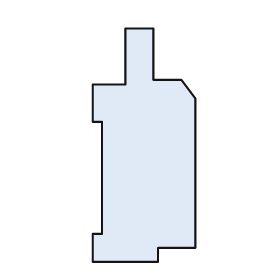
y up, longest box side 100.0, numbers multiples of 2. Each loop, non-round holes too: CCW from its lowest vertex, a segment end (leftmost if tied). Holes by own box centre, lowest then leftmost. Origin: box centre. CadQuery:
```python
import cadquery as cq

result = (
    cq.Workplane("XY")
    .moveTo(-22.0, -50.0)
    .lineTo(6.0, -50.0)
    .lineTo(6.0, -44.0)
    .lineTo(22.0, -44.0)
    .lineTo(22.0, 20.0)
    .lineTo(16.0, 28.0)
    .lineTo(4.0, 28.0)
    .lineTo(4.0, 50.0)
    .lineTo(-8.0, 50.0)
    .lineTo(-8.0, 26.0)
    .lineTo(-22.0, 26.0)
    .lineTo(-22.0, 10.0)
    .lineTo(-18.0, 10.0)
    .lineTo(-18.0, -38.0)
    .lineTo(-22.0, -38.0)
    .close()
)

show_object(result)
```